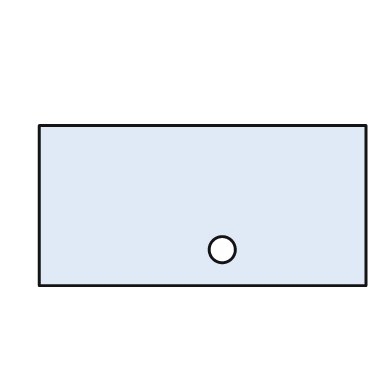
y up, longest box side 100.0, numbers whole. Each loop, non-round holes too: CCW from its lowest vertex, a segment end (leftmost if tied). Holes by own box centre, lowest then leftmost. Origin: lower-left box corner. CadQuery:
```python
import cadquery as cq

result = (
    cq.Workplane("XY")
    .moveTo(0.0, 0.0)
    .lineTo(100.0, 0.0)
    .lineTo(100.0, 49.0)
    .lineTo(0.0, 49.0)
    .close()
    .moveTo(56.0, 11.0)
    .circle(4.0)
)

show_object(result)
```